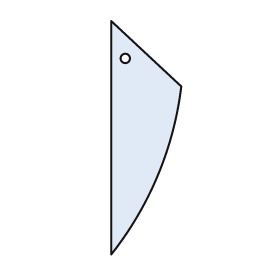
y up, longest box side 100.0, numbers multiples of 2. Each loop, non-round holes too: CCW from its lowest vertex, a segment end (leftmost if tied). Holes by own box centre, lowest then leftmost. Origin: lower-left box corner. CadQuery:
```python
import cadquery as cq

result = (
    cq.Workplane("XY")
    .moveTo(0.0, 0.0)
    .threePointArc((20.0, 34.0), (30.0, 72.0))
    .lineTo(0.0, 100.0)
    .close()
    .moveTo(6.0, 84.0)
    .circle(2.0)
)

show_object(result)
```